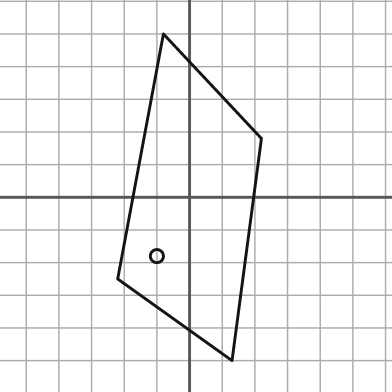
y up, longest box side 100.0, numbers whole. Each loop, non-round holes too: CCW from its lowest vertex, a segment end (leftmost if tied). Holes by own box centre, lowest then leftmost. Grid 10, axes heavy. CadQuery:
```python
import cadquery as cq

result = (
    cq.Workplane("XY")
    .moveTo(13.0, -50.0)
    .lineTo(22.0, 18.0)
    .lineTo(-8.0, 50.0)
    .lineTo(-22.0, -25.0)
    .close()
    .moveTo(-10.0, -18.0)
    .circle(2.0)
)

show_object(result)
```